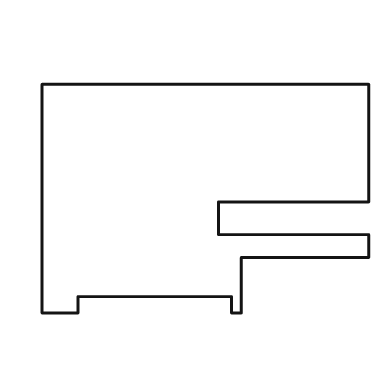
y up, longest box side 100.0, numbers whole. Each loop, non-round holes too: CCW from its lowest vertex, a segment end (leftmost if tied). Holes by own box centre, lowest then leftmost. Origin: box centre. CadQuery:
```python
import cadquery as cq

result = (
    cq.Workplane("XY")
    .moveTo(-50.0, -35.0)
    .lineTo(-39.0, -35.0)
    .lineTo(-39.0, -30.0)
    .lineTo(8.0, -30.0)
    .lineTo(8.0, -35.0)
    .lineTo(11.0, -35.0)
    .lineTo(11.0, -18.0)
    .lineTo(50.0, -18.0)
    .lineTo(50.0, -11.0)
    .lineTo(4.0, -11.0)
    .lineTo(4.0, -1.0)
    .lineTo(50.0, -1.0)
    .lineTo(50.0, 35.0)
    .lineTo(-50.0, 35.0)
    .close()
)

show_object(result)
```